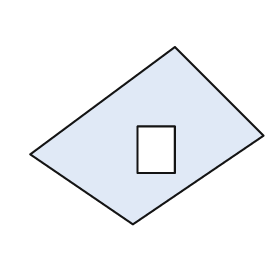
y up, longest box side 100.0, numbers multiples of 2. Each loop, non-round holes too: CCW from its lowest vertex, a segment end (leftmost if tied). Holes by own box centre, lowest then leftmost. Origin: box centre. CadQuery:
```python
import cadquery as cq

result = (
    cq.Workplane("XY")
    .moveTo(-6.0, -38.0)
    .lineTo(50.0, 0.0)
    .lineTo(12.0, 38.0)
    .lineTo(-50.0, -8.0)
    .close()
    .moveTo(-4.0, -16.0)
    .lineTo(12.0, -16.0)
    .lineTo(12.0, 4.0)
    .lineTo(-4.0, 4.0)
    .close()
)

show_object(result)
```